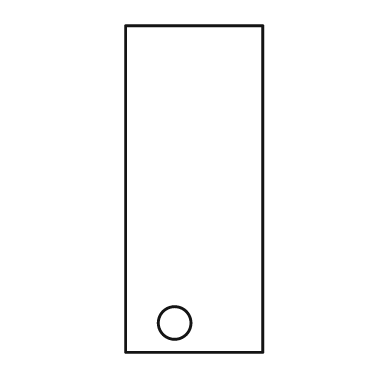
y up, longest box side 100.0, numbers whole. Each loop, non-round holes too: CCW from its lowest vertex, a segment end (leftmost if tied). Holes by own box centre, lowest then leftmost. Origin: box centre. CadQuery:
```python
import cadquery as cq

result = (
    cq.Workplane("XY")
    .moveTo(-21.0, -50.0)
    .lineTo(21.0, -50.0)
    .lineTo(21.0, 50.0)
    .lineTo(-21.0, 50.0)
    .close()
    .moveTo(-6.0, -41.0)
    .circle(5.0)
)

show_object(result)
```